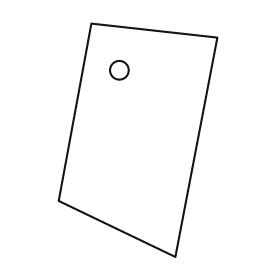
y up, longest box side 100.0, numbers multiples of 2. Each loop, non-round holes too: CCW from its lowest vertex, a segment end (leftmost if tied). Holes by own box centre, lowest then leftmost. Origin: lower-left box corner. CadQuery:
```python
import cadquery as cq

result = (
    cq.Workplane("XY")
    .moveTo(50.0, 0.0)
    .lineTo(68.0, 94.0)
    .lineTo(14.0, 100.0)
    .lineTo(0.0, 24.0)
    .close()
    .moveTo(26.0, 80.0)
    .circle(4.0)
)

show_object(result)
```